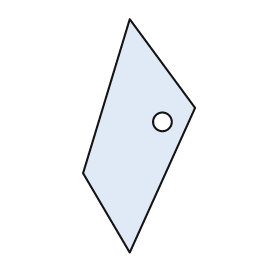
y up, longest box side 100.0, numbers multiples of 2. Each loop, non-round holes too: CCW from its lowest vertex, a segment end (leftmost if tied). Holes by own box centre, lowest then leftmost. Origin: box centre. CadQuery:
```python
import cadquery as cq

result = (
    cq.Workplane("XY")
    .moveTo(-4.0, -50.0)
    .lineTo(24.0, 12.0)
    .lineTo(-4.0, 50.0)
    .lineTo(-24.0, -16.0)
    .close()
    .moveTo(10.0, 6.0)
    .circle(4.0)
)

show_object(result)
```